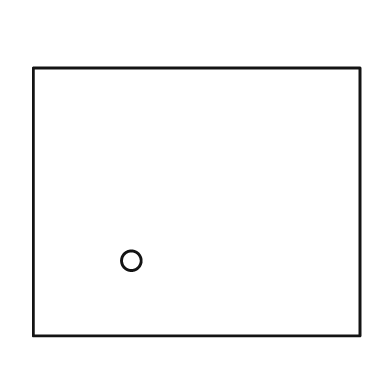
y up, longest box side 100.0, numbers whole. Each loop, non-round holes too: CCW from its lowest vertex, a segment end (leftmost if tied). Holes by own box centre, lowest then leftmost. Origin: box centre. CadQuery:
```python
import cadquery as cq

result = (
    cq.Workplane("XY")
    .moveTo(-50.0, -41.0)
    .lineTo(50.0, -41.0)
    .lineTo(50.0, 41.0)
    .lineTo(-50.0, 41.0)
    .close()
    .moveTo(-20.0, -18.0)
    .circle(3.0)
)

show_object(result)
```